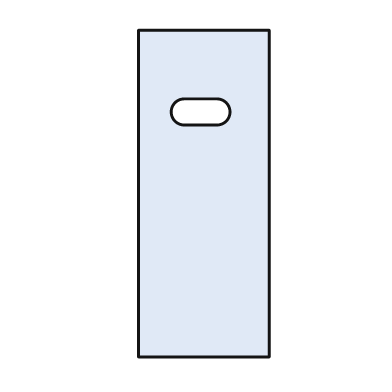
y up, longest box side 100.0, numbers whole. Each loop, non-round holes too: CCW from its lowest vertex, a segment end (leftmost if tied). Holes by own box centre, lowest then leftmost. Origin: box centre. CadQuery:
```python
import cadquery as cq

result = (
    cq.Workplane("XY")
    .moveTo(-20.0, -50.0)
    .lineTo(20.0, -50.0)
    .lineTo(20.0, 50.0)
    .lineTo(-20.0, 50.0)
    .close()
    .moveTo(-6.0, 21.0)
    .lineTo(4.0, 21.0)
    .threePointArc((8.0, 25.0), (4.0, 29.0))
    .lineTo(-6.0, 29.0)
    .threePointArc((-10.0, 25.0), (-6.0, 21.0))
    .close()
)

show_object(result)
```